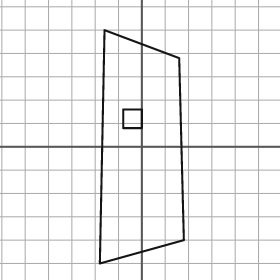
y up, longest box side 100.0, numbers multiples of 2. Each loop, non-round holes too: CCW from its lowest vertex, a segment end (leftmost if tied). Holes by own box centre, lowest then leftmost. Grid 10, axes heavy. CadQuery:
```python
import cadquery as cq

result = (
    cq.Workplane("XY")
    .moveTo(-18.0, -50.0)
    .lineTo(18.0, -40.0)
    .lineTo(16.0, 38.0)
    .lineTo(-16.0, 50.0)
    .close()
    .moveTo(-8.0, 8.0)
    .lineTo(0.0, 8.0)
    .lineTo(0.0, 16.0)
    .lineTo(-8.0, 16.0)
    .close()
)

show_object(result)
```